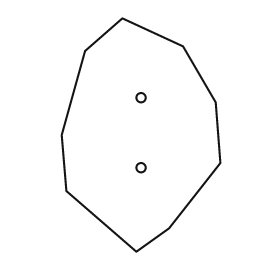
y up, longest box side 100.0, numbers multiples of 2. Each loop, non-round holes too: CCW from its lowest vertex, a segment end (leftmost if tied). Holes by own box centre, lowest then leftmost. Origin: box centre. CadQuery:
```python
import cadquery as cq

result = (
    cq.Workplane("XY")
    .moveTo(-2.0, -50.0)
    .lineTo(12.0, -40.0)
    .lineTo(34.0, -12.0)
    .lineTo(32.0, 14.0)
    .lineTo(18.0, 38.0)
    .lineTo(-8.0, 50.0)
    .lineTo(-24.0, 36.0)
    .lineTo(-34.0, 0.0)
    .lineTo(-32.0, -24.0)
    .close()
    .moveTo(0.0, -14.0)
    .circle(2.0)
    .moveTo(0.0, 16.0)
    .circle(2.0)
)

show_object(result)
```